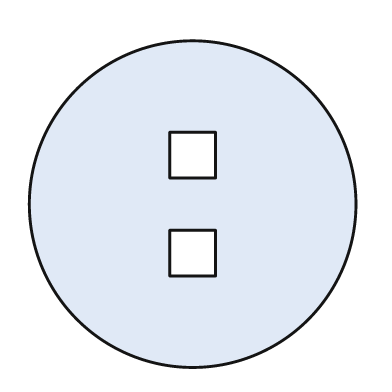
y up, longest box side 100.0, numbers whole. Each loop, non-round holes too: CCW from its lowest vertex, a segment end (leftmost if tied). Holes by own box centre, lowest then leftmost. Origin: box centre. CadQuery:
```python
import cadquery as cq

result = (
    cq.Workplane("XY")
    .moveTo(0.0, 0.0)
    .circle(50.0)
    .moveTo(-7.0, -22.0)
    .lineTo(7.0, -22.0)
    .lineTo(7.0, -8.0)
    .lineTo(-7.0, -8.0)
    .close()
    .moveTo(-7.0, 8.0)
    .lineTo(7.0, 8.0)
    .lineTo(7.0, 22.0)
    .lineTo(-7.0, 22.0)
    .close()
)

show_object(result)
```